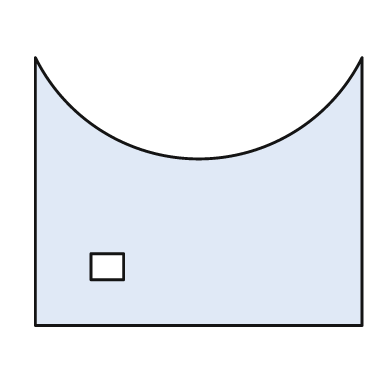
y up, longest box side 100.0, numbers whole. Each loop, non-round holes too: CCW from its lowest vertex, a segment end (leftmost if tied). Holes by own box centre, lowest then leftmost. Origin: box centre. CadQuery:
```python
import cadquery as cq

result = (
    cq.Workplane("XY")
    .moveTo(-50.0, -41.0)
    .lineTo(50.0, -41.0)
    .lineTo(50.0, 41.0)
    .threePointArc((0.0, 10.0), (-50.0, 41.0))
    .close()
    .moveTo(-33.0, -27.0)
    .lineTo(-23.0, -27.0)
    .lineTo(-23.0, -19.0)
    .lineTo(-33.0, -19.0)
    .close()
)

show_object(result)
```